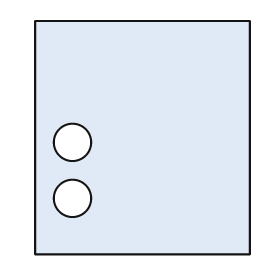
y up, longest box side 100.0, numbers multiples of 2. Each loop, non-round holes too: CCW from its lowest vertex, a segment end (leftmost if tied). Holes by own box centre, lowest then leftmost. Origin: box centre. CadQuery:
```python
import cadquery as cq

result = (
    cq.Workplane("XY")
    .moveTo(-46.0, -50.0)
    .lineTo(46.0, -50.0)
    .lineTo(46.0, 50.0)
    .lineTo(-46.0, 50.0)
    .close()
    .moveTo(-30.0, -26.0)
    .circle(8.0)
    .moveTo(-30.0, -2.0)
    .circle(8.0)
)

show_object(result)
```